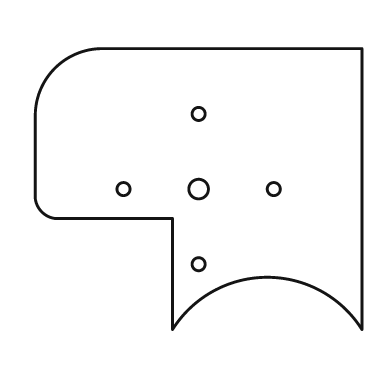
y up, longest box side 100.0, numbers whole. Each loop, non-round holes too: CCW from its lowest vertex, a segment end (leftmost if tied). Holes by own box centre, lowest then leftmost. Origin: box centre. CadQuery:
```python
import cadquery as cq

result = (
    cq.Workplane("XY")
    .moveTo(-8.0, -43.0)
    .threePointArc((21.0, -27.0), (50.0, -43.0))
    .lineTo(50.0, 43.0)
    .lineTo(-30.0, 43.0)
    .threePointArc((-44.0, 37.0), (-50.0, 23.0))
    .lineTo(-50.0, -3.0)
    .threePointArc((-48.0, -7.0), (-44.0, -9.0))
    .lineTo(-8.0, -9.0)
    .close()
    .moveTo(0.0, -23.0)
    .circle(2.0)
    .moveTo(-23.0, 0.0)
    .circle(2.0)
    .moveTo(0.0, 0.0)
    .circle(3.0)
    .moveTo(23.0, 0.0)
    .circle(2.0)
    .moveTo(0.0, 23.0)
    .circle(2.0)
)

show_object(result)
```